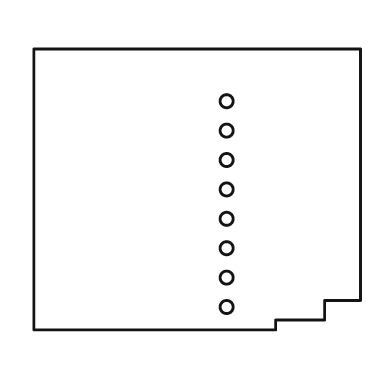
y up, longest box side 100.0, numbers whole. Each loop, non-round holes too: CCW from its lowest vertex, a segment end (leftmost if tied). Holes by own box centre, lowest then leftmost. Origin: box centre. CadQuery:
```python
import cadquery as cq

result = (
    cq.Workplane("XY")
    .moveTo(-50.0, -43.0)
    .lineTo(24.0, -43.0)
    .lineTo(24.0, -40.0)
    .lineTo(39.0, -40.0)
    .lineTo(39.0, -34.0)
    .lineTo(50.0, -34.0)
    .lineTo(50.0, 43.0)
    .lineTo(-50.0, 43.0)
    .close()
    .moveTo(9.0, -36.0)
    .circle(2.0)
    .moveTo(9.0, -27.0)
    .circle(2.0)
    .moveTo(9.0, -18.0)
    .circle(2.0)
    .moveTo(9.0, -9.0)
    .circle(2.0)
    .moveTo(9.0, 0.0)
    .circle(2.0)
    .moveTo(9.0, 9.0)
    .circle(2.0)
    .moveTo(9.0, 18.0)
    .circle(2.0)
    .moveTo(9.0, 27.0)
    .circle(2.0)
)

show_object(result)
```